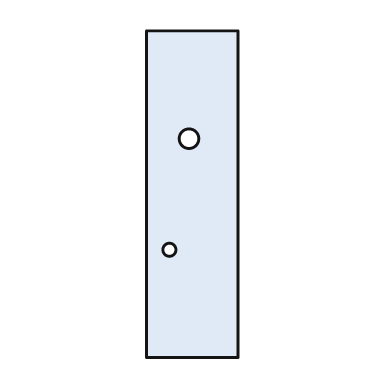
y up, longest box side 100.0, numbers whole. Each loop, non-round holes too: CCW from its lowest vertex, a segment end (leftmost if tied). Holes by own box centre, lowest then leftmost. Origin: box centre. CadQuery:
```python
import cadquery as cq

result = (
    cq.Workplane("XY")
    .moveTo(-14.0, -50.0)
    .lineTo(14.0, -50.0)
    .lineTo(14.0, 50.0)
    .lineTo(-14.0, 50.0)
    .close()
    .moveTo(-7.0, -17.0)
    .circle(2.0)
    .moveTo(-1.0, 17.0)
    .circle(3.0)
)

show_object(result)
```